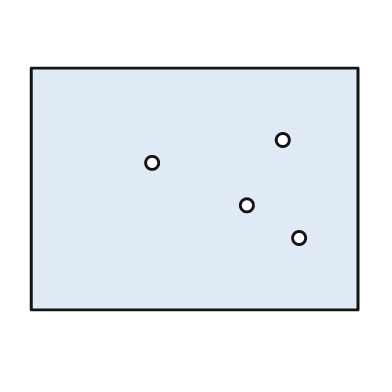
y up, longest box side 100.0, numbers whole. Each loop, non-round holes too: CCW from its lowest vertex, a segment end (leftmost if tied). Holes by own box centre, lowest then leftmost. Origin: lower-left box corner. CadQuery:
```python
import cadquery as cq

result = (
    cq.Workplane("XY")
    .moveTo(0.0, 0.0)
    .lineTo(100.0, 0.0)
    .lineTo(100.0, 74.0)
    .lineTo(0.0, 74.0)
    .close()
    .moveTo(82.0, 22.0)
    .circle(2.0)
    .moveTo(66.0, 32.0)
    .circle(2.0)
    .moveTo(37.0, 45.0)
    .circle(2.0)
    .moveTo(77.0, 52.0)
    .circle(2.0)
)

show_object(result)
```